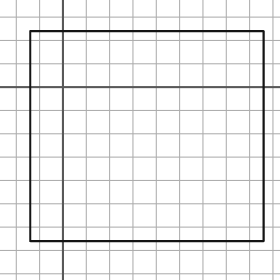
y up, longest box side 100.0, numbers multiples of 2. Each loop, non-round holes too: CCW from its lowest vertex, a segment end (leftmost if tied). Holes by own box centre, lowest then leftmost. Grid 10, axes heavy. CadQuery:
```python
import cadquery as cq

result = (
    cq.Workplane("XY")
    .moveTo(-14.0, -66.0)
    .lineTo(86.0, -66.0)
    .lineTo(86.0, 24.0)
    .lineTo(-14.0, 24.0)
    .close()
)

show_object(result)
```